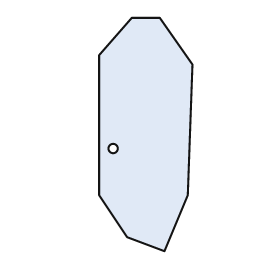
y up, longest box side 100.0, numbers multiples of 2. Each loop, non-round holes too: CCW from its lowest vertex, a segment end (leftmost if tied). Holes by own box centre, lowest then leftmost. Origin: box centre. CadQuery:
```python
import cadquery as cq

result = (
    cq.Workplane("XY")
    .moveTo(8.0, -50.0)
    .lineTo(18.0, -26.0)
    .lineTo(20.0, 30.0)
    .lineTo(6.0, 50.0)
    .lineTo(-6.0, 50.0)
    .lineTo(-20.0, 34.0)
    .lineTo(-20.0, -26.0)
    .lineTo(-8.0, -44.0)
    .close()
    .moveTo(-14.0, -6.0)
    .circle(2.0)
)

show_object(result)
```